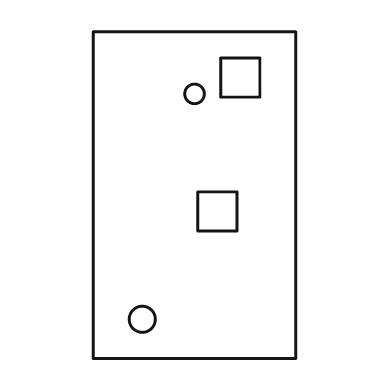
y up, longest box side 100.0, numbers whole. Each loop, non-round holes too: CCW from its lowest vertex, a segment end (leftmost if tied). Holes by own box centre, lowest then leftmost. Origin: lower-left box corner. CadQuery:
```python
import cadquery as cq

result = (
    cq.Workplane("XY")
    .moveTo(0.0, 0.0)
    .lineTo(62.0, 0.0)
    .lineTo(62.0, 100.0)
    .lineTo(0.0, 100.0)
    .close()
    .moveTo(15.0, 12.0)
    .circle(4.0)
    .moveTo(32.0, 39.0)
    .lineTo(44.0, 39.0)
    .lineTo(44.0, 51.0)
    .lineTo(32.0, 51.0)
    .close()
    .moveTo(31.0, 81.0)
    .circle(3.0)
    .moveTo(39.0, 80.0)
    .lineTo(51.0, 80.0)
    .lineTo(51.0, 92.0)
    .lineTo(39.0, 92.0)
    .close()
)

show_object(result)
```